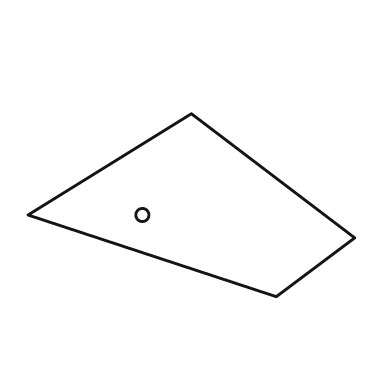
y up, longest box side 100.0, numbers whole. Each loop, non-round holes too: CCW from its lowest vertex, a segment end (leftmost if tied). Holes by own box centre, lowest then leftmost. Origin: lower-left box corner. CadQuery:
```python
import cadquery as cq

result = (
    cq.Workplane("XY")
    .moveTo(76.0, 0.0)
    .lineTo(100.0, 18.0)
    .lineTo(50.0, 56.0)
    .lineTo(0.0, 25.0)
    .close()
    .moveTo(35.0, 25.0)
    .circle(2.0)
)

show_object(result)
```